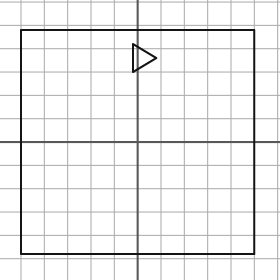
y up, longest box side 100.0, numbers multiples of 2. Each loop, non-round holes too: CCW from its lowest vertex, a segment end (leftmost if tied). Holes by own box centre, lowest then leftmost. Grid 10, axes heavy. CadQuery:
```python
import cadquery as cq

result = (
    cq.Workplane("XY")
    .moveTo(-50.0, -48.0)
    .lineTo(50.0, -48.0)
    .lineTo(50.0, 48.0)
    .lineTo(-50.0, 48.0)
    .close()
    .moveTo(-2.0, 30.0)
    .lineTo(8.0, 36.0)
    .lineTo(-2.0, 42.0)
    .close()
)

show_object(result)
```